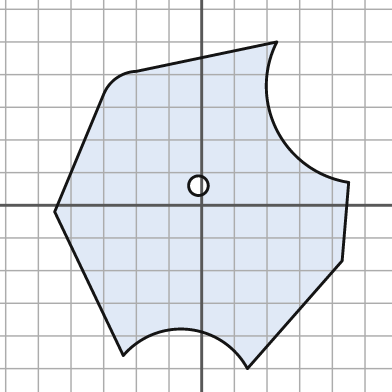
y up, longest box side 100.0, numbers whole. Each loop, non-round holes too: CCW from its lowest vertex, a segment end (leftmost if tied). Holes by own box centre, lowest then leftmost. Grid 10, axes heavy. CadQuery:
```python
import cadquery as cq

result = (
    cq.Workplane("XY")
    .moveTo(14.0, -50.0)
    .lineTo(43.0, -17.0)
    .lineTo(45.0, 7.0)
    .threePointArc((23.0, 23.0), (23.0, 50.0))
    .lineTo(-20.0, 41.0)
    .threePointArc((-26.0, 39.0), (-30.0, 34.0))
    .lineTo(-45.0, -2.0)
    .lineTo(-24.0, -46.0)
    .threePointArc((-4.0, -38.0), (14.0, -50.0))
    .close()
    .moveTo(-1.0, 6.0)
    .circle(3.0)
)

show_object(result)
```